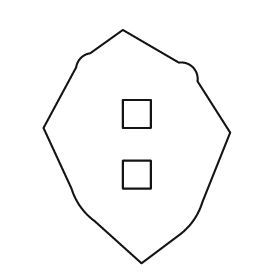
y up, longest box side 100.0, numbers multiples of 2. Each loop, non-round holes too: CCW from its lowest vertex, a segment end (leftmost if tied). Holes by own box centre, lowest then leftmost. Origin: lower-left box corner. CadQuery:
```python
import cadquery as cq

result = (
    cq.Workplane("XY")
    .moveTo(42.0, 0.0)
    .lineTo(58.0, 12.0)
    .threePointArc((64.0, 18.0), (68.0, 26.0))
    .lineTo(80.0, 56.0)
    .lineTo(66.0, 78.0)
    .threePointArc((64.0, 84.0), (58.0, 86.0))
    .lineTo(34.0, 100.0)
    .lineTo(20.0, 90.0)
    .threePointArc((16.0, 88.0), (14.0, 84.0))
    .lineTo(0.0, 58.0)
    .lineTo(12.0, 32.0)
    .threePointArc((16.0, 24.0), (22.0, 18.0))
    .close()
    .moveTo(34.0, 32.0)
    .lineTo(46.0, 32.0)
    .lineTo(46.0, 44.0)
    .lineTo(34.0, 44.0)
    .close()
    .moveTo(34.0, 58.0)
    .lineTo(46.0, 58.0)
    .lineTo(46.0, 70.0)
    .lineTo(34.0, 70.0)
    .close()
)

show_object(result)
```